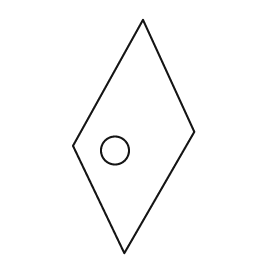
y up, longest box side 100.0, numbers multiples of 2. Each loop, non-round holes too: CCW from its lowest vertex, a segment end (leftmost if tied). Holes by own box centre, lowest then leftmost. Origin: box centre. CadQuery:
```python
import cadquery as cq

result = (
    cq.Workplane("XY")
    .moveTo(-4.0, -50.0)
    .lineTo(26.0, 2.0)
    .lineTo(4.0, 50.0)
    .lineTo(-26.0, -4.0)
    .close()
    .moveTo(-8.0, -6.0)
    .circle(6.0)
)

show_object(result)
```